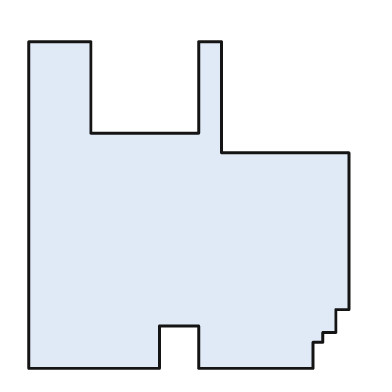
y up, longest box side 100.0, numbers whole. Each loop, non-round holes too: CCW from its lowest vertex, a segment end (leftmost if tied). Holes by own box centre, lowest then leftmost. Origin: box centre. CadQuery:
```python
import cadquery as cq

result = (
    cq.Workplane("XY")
    .moveTo(-49.0, -50.0)
    .lineTo(-9.0, -50.0)
    .lineTo(-9.0, -37.0)
    .lineTo(3.0, -37.0)
    .lineTo(3.0, -50.0)
    .lineTo(38.0, -50.0)
    .lineTo(38.0, -42.0)
    .lineTo(41.0, -42.0)
    .lineTo(41.0, -39.0)
    .lineTo(45.0, -39.0)
    .lineTo(45.0, -32.0)
    .lineTo(49.0, -32.0)
    .lineTo(49.0, 16.0)
    .lineTo(10.0, 16.0)
    .lineTo(10.0, 50.0)
    .lineTo(3.0, 50.0)
    .lineTo(3.0, 22.0)
    .lineTo(-30.0, 22.0)
    .lineTo(-30.0, 50.0)
    .lineTo(-49.0, 50.0)
    .close()
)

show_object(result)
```